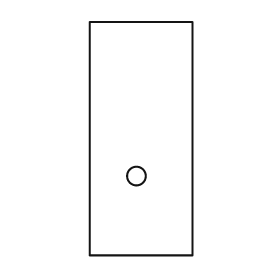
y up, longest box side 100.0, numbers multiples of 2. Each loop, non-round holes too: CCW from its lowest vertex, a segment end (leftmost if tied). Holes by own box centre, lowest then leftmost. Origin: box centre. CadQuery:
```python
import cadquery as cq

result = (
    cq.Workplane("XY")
    .moveTo(-22.0, -50.0)
    .lineTo(22.0, -50.0)
    .lineTo(22.0, 50.0)
    .lineTo(-22.0, 50.0)
    .close()
    .moveTo(-2.0, -16.0)
    .circle(4.0)
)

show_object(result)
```